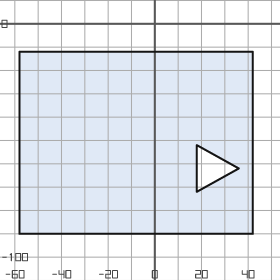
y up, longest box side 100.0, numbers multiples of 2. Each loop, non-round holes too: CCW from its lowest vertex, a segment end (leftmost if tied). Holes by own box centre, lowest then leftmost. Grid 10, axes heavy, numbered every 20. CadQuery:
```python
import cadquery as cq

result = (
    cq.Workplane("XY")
    .moveTo(-58.0, -90.0)
    .lineTo(42.0, -90.0)
    .lineTo(42.0, -12.0)
    .lineTo(-58.0, -12.0)
    .close()
    .moveTo(18.0, -72.0)
    .lineTo(36.0, -62.0)
    .lineTo(18.0, -52.0)
    .close()
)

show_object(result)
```